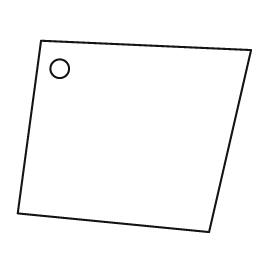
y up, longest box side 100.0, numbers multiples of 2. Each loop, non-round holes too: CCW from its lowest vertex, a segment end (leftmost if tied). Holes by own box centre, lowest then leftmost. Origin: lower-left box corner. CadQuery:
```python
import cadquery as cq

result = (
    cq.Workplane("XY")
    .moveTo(82.0, 0.0)
    .lineTo(100.0, 78.0)
    .lineTo(10.0, 82.0)
    .lineTo(0.0, 8.0)
    .close()
    .moveTo(18.0, 70.0)
    .circle(4.0)
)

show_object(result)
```